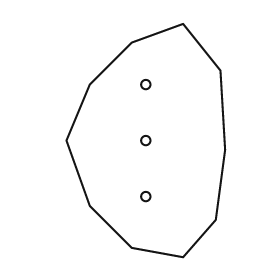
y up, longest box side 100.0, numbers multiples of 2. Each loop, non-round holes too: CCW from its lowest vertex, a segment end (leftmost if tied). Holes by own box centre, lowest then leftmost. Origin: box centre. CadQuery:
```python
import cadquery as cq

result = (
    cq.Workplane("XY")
    .moveTo(16.0, -50.0)
    .lineTo(30.0, -34.0)
    .lineTo(34.0, -4.0)
    .lineTo(32.0, 30.0)
    .lineTo(16.0, 50.0)
    .lineTo(-6.0, 42.0)
    .lineTo(-24.0, 24.0)
    .lineTo(-34.0, 0.0)
    .lineTo(-24.0, -28.0)
    .lineTo(-6.0, -46.0)
    .close()
    .moveTo(0.0, -24.0)
    .circle(2.0)
    .moveTo(0.0, 0.0)
    .circle(2.0)
    .moveTo(0.0, 24.0)
    .circle(2.0)
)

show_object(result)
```